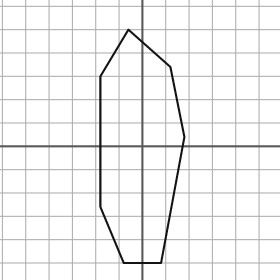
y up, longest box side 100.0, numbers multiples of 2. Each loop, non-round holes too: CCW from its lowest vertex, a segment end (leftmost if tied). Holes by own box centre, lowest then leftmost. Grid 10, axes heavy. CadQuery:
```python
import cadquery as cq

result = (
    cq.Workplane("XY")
    .moveTo(-8.0, -50.0)
    .lineTo(8.0, -50.0)
    .lineTo(18.0, 4.0)
    .lineTo(12.0, 34.0)
    .lineTo(-6.0, 50.0)
    .lineTo(-18.0, 30.0)
    .lineTo(-18.0, -26.0)
    .close()
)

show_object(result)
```